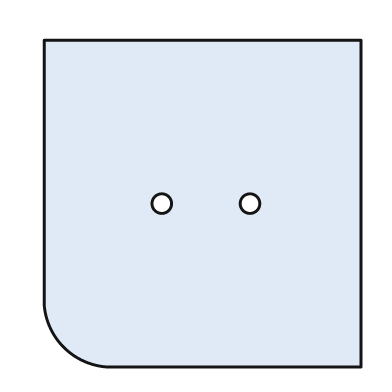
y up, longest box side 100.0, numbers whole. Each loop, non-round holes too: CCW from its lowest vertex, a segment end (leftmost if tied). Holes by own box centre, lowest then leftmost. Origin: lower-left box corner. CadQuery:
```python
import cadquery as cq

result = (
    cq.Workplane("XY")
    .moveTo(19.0, 0.0)
    .lineTo(97.0, 0.0)
    .lineTo(97.0, 100.0)
    .lineTo(0.0, 100.0)
    .lineTo(0.0, 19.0)
    .threePointArc((6.0, 6.0), (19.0, 0.0))
    .close()
    .moveTo(36.0, 50.0)
    .circle(3.0)
    .moveTo(63.0, 50.0)
    .circle(3.0)
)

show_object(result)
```